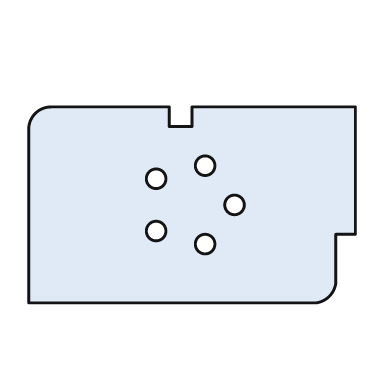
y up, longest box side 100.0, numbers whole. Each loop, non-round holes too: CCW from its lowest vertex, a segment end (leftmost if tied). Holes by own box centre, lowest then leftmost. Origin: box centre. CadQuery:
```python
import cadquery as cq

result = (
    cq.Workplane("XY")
    .moveTo(-50.0, -30.0)
    .lineTo(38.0, -30.0)
    .threePointArc((42.0, -28.0), (44.0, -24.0))
    .lineTo(44.0, -9.0)
    .lineTo(50.0, -9.0)
    .lineTo(50.0, 30.0)
    .lineTo(0.0, 30.0)
    .lineTo(0.0, 24.0)
    .lineTo(-7.0, 24.0)
    .lineTo(-7.0, 30.0)
    .lineTo(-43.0, 30.0)
    .threePointArc((-48.0, 28.0), (-50.0, 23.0))
    .close()
    .moveTo(4.0, -12.0)
    .circle(3.0)
    .moveTo(-11.0, -8.0)
    .circle(3.0)
    .moveTo(13.0, 0.0)
    .circle(3.0)
    .moveTo(-11.0, 8.0)
    .circle(3.0)
    .moveTo(4.0, 12.0)
    .circle(3.0)
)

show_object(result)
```